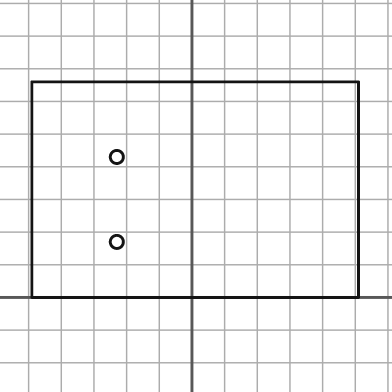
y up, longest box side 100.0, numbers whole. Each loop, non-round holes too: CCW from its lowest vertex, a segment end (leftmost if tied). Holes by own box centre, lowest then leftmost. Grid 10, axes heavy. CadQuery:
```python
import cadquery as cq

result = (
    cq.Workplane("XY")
    .moveTo(-49.0, 0.0)
    .lineTo(51.0, 0.0)
    .lineTo(51.0, 66.0)
    .lineTo(-49.0, 66.0)
    .close()
    .moveTo(-23.0, 17.0)
    .circle(2.0)
    .moveTo(-23.0, 43.0)
    .circle(2.0)
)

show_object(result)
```